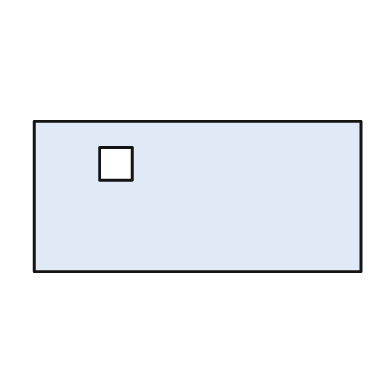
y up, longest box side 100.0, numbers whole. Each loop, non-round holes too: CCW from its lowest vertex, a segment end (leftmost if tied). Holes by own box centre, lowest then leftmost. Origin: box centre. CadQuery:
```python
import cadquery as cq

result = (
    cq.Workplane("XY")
    .moveTo(-50.0, -23.0)
    .lineTo(50.0, -23.0)
    .lineTo(50.0, 23.0)
    .lineTo(-50.0, 23.0)
    .close()
    .moveTo(-30.0, 5.0)
    .lineTo(-20.0, 5.0)
    .lineTo(-20.0, 15.0)
    .lineTo(-30.0, 15.0)
    .close()
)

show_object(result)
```